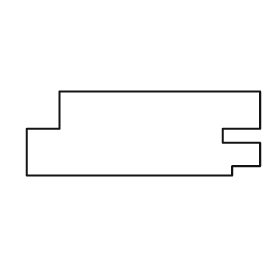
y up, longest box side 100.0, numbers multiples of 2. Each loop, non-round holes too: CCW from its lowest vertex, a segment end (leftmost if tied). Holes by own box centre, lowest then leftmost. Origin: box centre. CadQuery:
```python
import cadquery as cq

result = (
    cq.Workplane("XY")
    .moveTo(-50.0, -18.0)
    .lineTo(38.0, -18.0)
    .lineTo(38.0, -14.0)
    .lineTo(50.0, -14.0)
    .lineTo(50.0, -4.0)
    .lineTo(34.0, -4.0)
    .lineTo(34.0, 2.0)
    .lineTo(50.0, 2.0)
    .lineTo(50.0, 18.0)
    .lineTo(-36.0, 18.0)
    .lineTo(-36.0, 2.0)
    .lineTo(-50.0, 2.0)
    .close()
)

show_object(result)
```